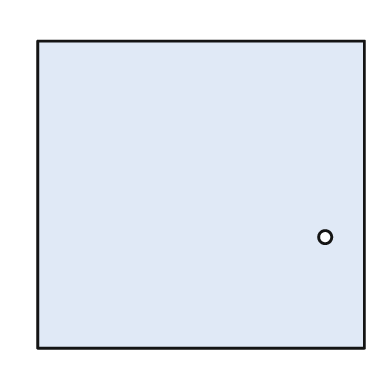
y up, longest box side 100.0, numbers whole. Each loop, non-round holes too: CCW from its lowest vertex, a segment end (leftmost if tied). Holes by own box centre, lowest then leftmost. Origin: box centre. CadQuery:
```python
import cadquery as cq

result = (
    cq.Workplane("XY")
    .moveTo(-50.0, -47.0)
    .lineTo(50.0, -47.0)
    .lineTo(50.0, 47.0)
    .lineTo(-50.0, 47.0)
    .close()
    .moveTo(38.0, -13.0)
    .circle(2.0)
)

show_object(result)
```